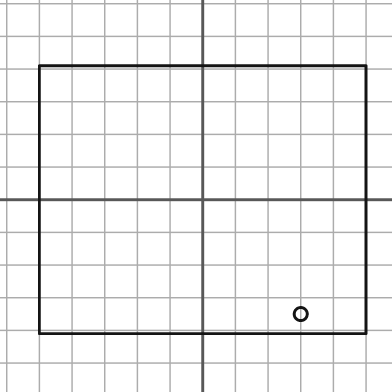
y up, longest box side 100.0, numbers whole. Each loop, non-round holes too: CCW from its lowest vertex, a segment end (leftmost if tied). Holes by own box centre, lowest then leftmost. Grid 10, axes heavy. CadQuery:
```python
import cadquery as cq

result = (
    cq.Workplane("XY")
    .moveTo(-50.0, -41.0)
    .lineTo(50.0, -41.0)
    .lineTo(50.0, 41.0)
    .lineTo(-50.0, 41.0)
    .close()
    .moveTo(30.0, -35.0)
    .circle(2.0)
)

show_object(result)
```